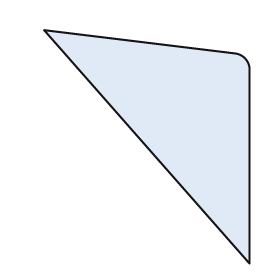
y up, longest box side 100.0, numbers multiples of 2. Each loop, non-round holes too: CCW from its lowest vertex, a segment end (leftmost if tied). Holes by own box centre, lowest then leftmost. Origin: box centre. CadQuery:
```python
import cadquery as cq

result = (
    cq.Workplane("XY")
    .moveTo(44.0, -50.0)
    .lineTo(44.0, 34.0)
    .threePointArc((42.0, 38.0), (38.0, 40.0))
    .lineTo(-44.0, 50.0)
    .close()
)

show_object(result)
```